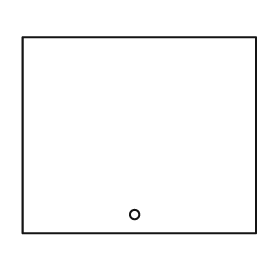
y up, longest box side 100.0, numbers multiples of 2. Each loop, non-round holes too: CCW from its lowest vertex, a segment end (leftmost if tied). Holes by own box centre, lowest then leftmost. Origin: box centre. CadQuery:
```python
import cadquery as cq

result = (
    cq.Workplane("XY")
    .moveTo(-50.0, -42.0)
    .lineTo(50.0, -42.0)
    .lineTo(50.0, 42.0)
    .lineTo(-50.0, 42.0)
    .close()
    .moveTo(-2.0, -34.0)
    .circle(2.0)
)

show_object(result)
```